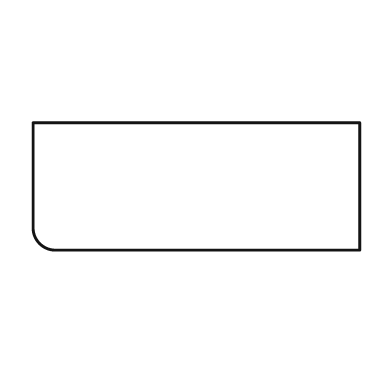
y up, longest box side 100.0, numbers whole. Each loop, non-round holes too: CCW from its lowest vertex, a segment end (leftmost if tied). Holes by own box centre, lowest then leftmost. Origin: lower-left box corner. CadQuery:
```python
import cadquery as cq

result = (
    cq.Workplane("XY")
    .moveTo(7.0, 0.0)
    .lineTo(100.0, 0.0)
    .lineTo(100.0, 39.0)
    .lineTo(0.0, 39.0)
    .lineTo(0.0, 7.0)
    .threePointArc((2.0, 2.0), (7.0, 0.0))
    .close()
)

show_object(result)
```